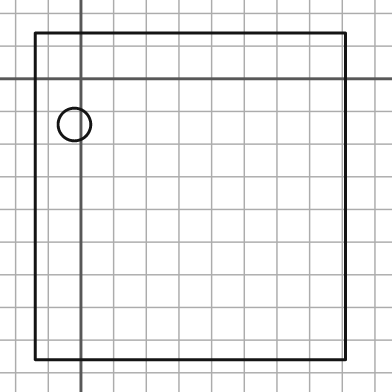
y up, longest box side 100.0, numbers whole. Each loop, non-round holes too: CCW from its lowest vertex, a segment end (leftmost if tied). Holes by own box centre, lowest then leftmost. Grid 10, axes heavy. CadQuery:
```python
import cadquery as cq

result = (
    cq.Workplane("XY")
    .moveTo(-14.0, -86.0)
    .lineTo(81.0, -86.0)
    .lineTo(81.0, 14.0)
    .lineTo(-14.0, 14.0)
    .close()
    .moveTo(-2.0, -14.0)
    .circle(5.0)
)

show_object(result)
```